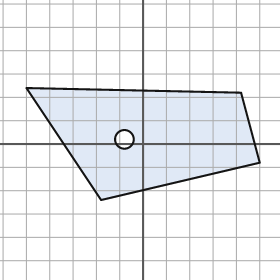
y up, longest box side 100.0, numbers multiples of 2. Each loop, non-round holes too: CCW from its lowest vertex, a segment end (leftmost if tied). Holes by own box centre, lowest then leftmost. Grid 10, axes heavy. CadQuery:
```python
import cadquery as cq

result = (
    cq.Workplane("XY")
    .moveTo(-18.0, -24.0)
    .lineTo(50.0, -8.0)
    .lineTo(42.0, 22.0)
    .lineTo(-50.0, 24.0)
    .close()
    .moveTo(-8.0, 2.0)
    .circle(4.0)
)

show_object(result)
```